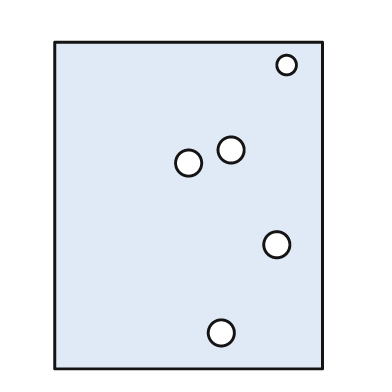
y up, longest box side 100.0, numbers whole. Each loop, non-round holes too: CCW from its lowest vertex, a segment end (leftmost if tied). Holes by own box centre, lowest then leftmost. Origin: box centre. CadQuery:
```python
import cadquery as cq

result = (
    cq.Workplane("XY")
    .moveTo(-41.0, -50.0)
    .lineTo(41.0, -50.0)
    .lineTo(41.0, 50.0)
    .lineTo(-41.0, 50.0)
    .close()
    .moveTo(10.0, -39.0)
    .circle(4.0)
    .moveTo(27.0, -12.0)
    .circle(4.0)
    .moveTo(0.0, 13.0)
    .circle(4.0)
    .moveTo(13.0, 17.0)
    .circle(4.0)
    .moveTo(30.0, 43.0)
    .circle(3.0)
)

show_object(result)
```